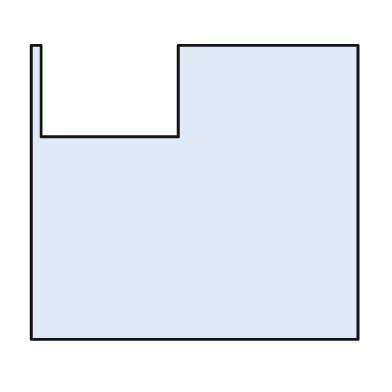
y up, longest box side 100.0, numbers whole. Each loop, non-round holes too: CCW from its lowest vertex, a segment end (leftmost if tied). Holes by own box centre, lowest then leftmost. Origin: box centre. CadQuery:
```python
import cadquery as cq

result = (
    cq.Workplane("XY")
    .moveTo(-50.0, -45.0)
    .lineTo(50.0, -45.0)
    .lineTo(50.0, 45.0)
    .lineTo(-5.0, 45.0)
    .lineTo(-5.0, 17.0)
    .lineTo(-47.0, 17.0)
    .lineTo(-47.0, 45.0)
    .lineTo(-50.0, 45.0)
    .close()
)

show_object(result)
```